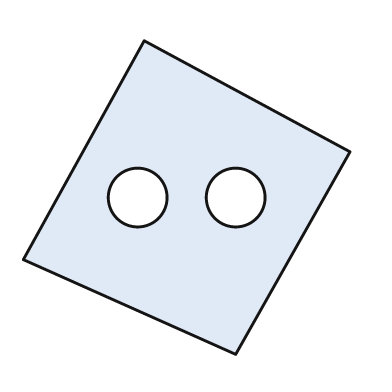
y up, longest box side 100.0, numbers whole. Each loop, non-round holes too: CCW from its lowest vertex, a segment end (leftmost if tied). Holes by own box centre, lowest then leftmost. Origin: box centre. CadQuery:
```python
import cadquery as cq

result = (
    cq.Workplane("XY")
    .moveTo(15.0, -48.0)
    .lineTo(50.0, 14.0)
    .lineTo(-13.0, 48.0)
    .lineTo(-50.0, -19.0)
    .close()
    .moveTo(-15.0, 0.0)
    .circle(9.0)
    .moveTo(15.0, 0.0)
    .circle(9.0)
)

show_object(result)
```